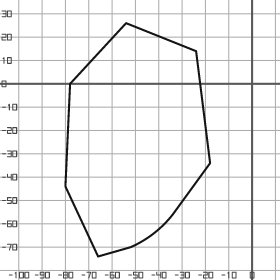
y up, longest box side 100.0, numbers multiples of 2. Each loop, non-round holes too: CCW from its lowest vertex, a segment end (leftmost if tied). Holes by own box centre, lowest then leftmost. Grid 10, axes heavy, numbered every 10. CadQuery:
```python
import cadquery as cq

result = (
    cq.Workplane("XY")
    .moveTo(-66.0, -74.0)
    .lineTo(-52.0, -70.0)
    .threePointArc((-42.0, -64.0), (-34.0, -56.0))
    .lineTo(-18.0, -34.0)
    .lineTo(-24.0, 14.0)
    .lineTo(-54.0, 26.0)
    .lineTo(-78.0, 0.0)
    .lineTo(-80.0, -44.0)
    .close()
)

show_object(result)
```